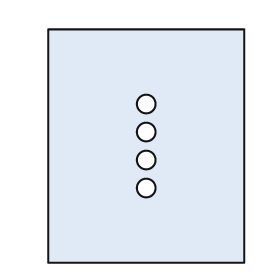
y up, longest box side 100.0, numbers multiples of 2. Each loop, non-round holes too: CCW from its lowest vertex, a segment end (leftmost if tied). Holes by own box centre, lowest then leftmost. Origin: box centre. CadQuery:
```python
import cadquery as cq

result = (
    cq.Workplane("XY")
    .moveTo(-42.0, -50.0)
    .lineTo(42.0, -50.0)
    .lineTo(42.0, 50.0)
    .lineTo(-42.0, 50.0)
    .close()
    .moveTo(0.0, -18.0)
    .circle(4.0)
    .moveTo(0.0, -6.0)
    .circle(4.0)
    .moveTo(0.0, 6.0)
    .circle(4.0)
    .moveTo(0.0, 18.0)
    .circle(4.0)
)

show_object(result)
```